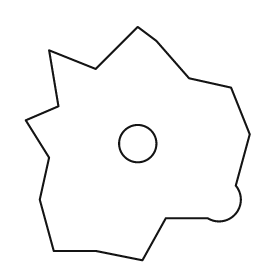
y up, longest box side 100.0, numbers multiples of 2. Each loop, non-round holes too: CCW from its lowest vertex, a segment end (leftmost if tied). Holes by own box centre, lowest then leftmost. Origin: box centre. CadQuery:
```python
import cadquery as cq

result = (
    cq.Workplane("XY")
    .moveTo(2.0, -50.0)
    .lineTo(12.0, -32.0)
    .lineTo(30.0, -32.0)
    .threePointArc((42.0, -30.0), (42.0, -18.0))
    .lineTo(48.0, 4.0)
    .lineTo(40.0, 24.0)
    .lineTo(22.0, 28.0)
    .lineTo(8.0, 44.0)
    .lineTo(0.0, 50.0)
    .lineTo(-18.0, 32.0)
    .lineTo(-38.0, 40.0)
    .lineTo(-34.0, 16.0)
    .lineTo(-48.0, 10.0)
    .lineTo(-38.0, -6.0)
    .lineTo(-42.0, -24.0)
    .lineTo(-36.0, -46.0)
    .lineTo(-18.0, -46.0)
    .close()
    .moveTo(0.0, 0.0)
    .circle(8.0)
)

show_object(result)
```